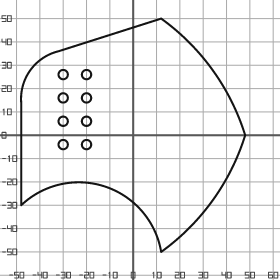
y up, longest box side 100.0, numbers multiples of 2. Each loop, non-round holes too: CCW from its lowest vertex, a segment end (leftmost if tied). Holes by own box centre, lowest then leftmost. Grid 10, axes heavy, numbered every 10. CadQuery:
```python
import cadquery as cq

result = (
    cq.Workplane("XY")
    .moveTo(12.0, -50.0)
    .threePointArc((34.0, -28.0), (48.0, 0.0))
    .threePointArc((34.0, 28.0), (12.0, 50.0))
    .lineTo(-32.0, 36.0)
    .threePointArc((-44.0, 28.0), (-48.0, 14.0))
    .lineTo(-48.0, -30.0)
    .threePointArc((-12.0, -22.0), (12.0, -50.0))
    .close()
    .moveTo(-30.0, -4.0)
    .circle(2.0)
    .moveTo(-20.0, -4.0)
    .circle(2.0)
    .moveTo(-30.0, 6.0)
    .circle(2.0)
    .moveTo(-20.0, 6.0)
    .circle(2.0)
    .moveTo(-30.0, 16.0)
    .circle(2.0)
    .moveTo(-20.0, 16.0)
    .circle(2.0)
    .moveTo(-30.0, 26.0)
    .circle(2.0)
    .moveTo(-20.0, 26.0)
    .circle(2.0)
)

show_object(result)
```